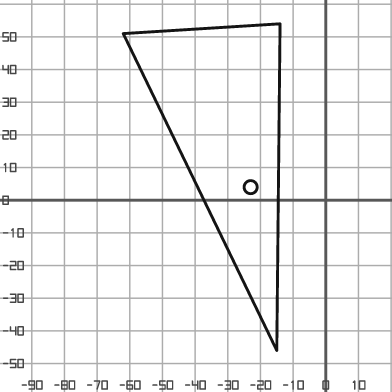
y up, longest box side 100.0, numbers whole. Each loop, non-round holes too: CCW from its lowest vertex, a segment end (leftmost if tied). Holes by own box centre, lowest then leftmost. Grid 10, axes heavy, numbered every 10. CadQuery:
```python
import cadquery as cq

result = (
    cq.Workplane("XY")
    .moveTo(-15.0, -46.0)
    .lineTo(-14.0, 54.0)
    .lineTo(-62.0, 51.0)
    .close()
    .moveTo(-23.0, 4.0)
    .circle(2.0)
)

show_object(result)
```